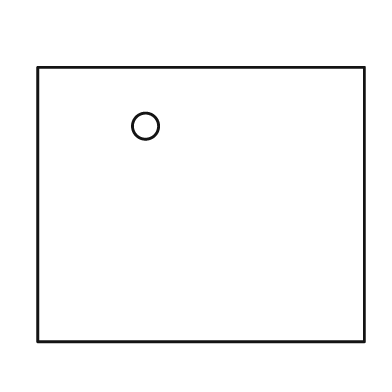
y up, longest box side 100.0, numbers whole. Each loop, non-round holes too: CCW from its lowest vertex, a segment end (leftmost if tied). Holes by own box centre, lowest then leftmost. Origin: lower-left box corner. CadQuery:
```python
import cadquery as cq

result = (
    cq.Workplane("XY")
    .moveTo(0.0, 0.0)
    .lineTo(100.0, 0.0)
    .lineTo(100.0, 84.0)
    .lineTo(0.0, 84.0)
    .close()
    .moveTo(33.0, 66.0)
    .circle(4.0)
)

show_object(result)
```